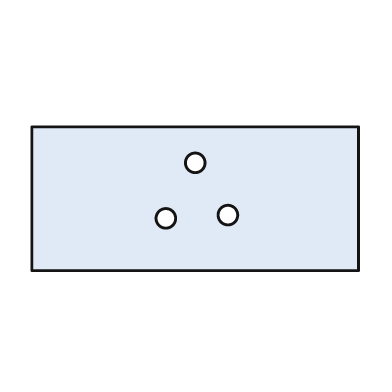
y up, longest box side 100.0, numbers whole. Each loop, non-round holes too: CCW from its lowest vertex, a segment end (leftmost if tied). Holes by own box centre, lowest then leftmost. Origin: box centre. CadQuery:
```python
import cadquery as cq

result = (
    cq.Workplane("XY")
    .moveTo(-50.0, -22.0)
    .lineTo(50.0, -22.0)
    .lineTo(50.0, 22.0)
    .lineTo(-50.0, 22.0)
    .close()
    .moveTo(-9.0, -6.0)
    .circle(3.0)
    .moveTo(10.0, -5.0)
    .circle(3.0)
    .moveTo(0.0, 11.0)
    .circle(3.0)
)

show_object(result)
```